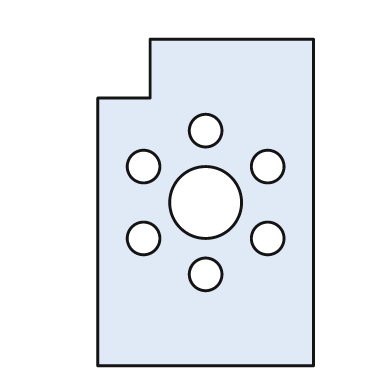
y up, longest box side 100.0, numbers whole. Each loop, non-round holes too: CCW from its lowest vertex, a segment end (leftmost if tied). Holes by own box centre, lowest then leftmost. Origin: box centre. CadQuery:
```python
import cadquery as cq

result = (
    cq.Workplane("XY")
    .moveTo(-33.0, -50.0)
    .lineTo(33.0, -50.0)
    .lineTo(33.0, 50.0)
    .lineTo(-17.0, 50.0)
    .lineTo(-17.0, 32.0)
    .lineTo(-33.0, 32.0)
    .close()
    .moveTo(0.0, -22.0)
    .circle(5.0)
    .moveTo(-19.0, -11.0)
    .circle(5.0)
    .moveTo(19.0, -11.0)
    .circle(5.0)
    .moveTo(0.0, 0.0)
    .circle(11.0)
    .moveTo(-19.0, 11.0)
    .circle(5.0)
    .moveTo(19.0, 11.0)
    .circle(5.0)
    .moveTo(0.0, 22.0)
    .circle(5.0)
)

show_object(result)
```